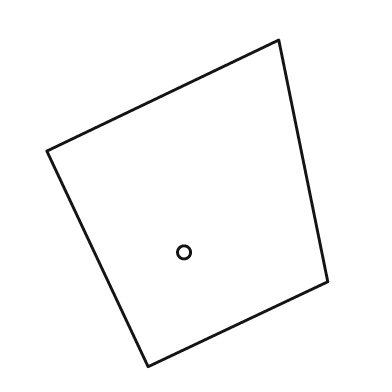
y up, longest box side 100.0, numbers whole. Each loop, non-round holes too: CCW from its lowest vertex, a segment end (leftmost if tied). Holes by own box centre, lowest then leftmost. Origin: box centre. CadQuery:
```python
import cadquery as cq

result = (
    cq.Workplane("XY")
    .moveTo(-12.0, -50.0)
    .lineTo(43.0, -24.0)
    .lineTo(28.0, 50.0)
    .lineTo(-43.0, 16.0)
    .close()
    .moveTo(-1.0, -15.0)
    .circle(2.0)
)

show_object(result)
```